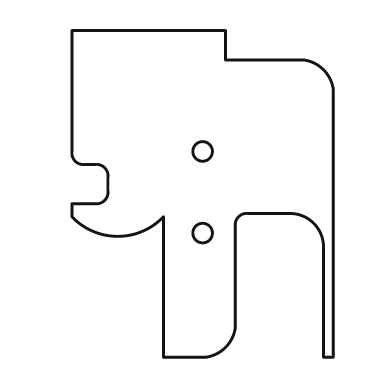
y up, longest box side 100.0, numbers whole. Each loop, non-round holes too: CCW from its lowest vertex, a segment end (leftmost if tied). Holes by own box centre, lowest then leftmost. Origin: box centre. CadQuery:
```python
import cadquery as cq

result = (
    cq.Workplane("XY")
    .moveTo(-12.0, -50.0)
    .lineTo(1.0, -50.0)
    .threePointArc((7.0, -47.0), (10.0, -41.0))
    .lineTo(10.0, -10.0)
    .threePointArc((11.0, -7.0), (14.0, -6.0))
    .lineTo(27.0, -6.0)
    .threePointArc((34.0, -9.0), (37.0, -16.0))
    .lineTo(37.0, -50.0)
    .lineTo(40.0, -50.0)
    .lineTo(40.0, 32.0)
    .threePointArc((37.0, 38.0), (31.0, 41.0))
    .lineTo(7.0, 41.0)
    .lineTo(7.0, 50.0)
    .lineTo(-40.0, 50.0)
    .lineTo(-40.0, 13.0)
    .threePointArc((-39.0, 10.0), (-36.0, 9.0))
    .lineTo(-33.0, 9.0)
    .threePointArc((-30.0, 8.0), (-29.0, 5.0))
    .lineTo(-29.0, 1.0)
    .threePointArc((-30.0, -2.0), (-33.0, -3.0))
    .lineTo(-40.0, -3.0)
    .lineTo(-40.0, -7.0)
    .threePointArc((-26.0, -13.0), (-12.0, -7.0))
    .close()
    .moveTo(0.0, -12.0)
    .circle(3.0)
    .moveTo(0.0, 13.0)
    .circle(3.0)
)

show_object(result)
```